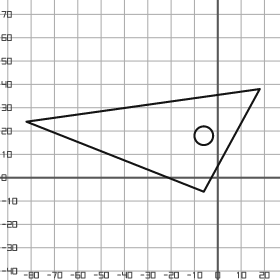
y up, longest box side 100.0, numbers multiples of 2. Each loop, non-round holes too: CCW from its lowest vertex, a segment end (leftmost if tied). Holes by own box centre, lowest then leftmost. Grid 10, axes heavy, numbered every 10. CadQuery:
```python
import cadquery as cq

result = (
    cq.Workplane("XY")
    .moveTo(-6.0, -6.0)
    .lineTo(18.0, 38.0)
    .lineTo(-82.0, 24.0)
    .close()
    .moveTo(-6.0, 18.0)
    .circle(4.0)
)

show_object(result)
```